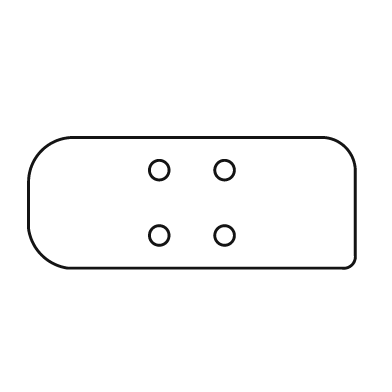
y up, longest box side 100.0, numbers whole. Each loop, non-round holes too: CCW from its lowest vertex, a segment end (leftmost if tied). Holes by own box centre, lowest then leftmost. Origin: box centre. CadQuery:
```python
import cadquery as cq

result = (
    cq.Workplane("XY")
    .moveTo(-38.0, -20.0)
    .lineTo(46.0, -20.0)
    .threePointArc((49.0, -19.0), (50.0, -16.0))
    .lineTo(50.0, 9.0)
    .threePointArc((47.0, 17.0), (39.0, 20.0))
    .lineTo(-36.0, 20.0)
    .threePointArc((-46.0, 16.0), (-50.0, 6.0))
    .lineTo(-50.0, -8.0)
    .threePointArc((-46.0, -16.0), (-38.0, -20.0))
    .close()
    .moveTo(-10.0, -10.0)
    .circle(3.0)
    .moveTo(10.0, -10.0)
    .circle(3.0)
    .moveTo(-10.0, 10.0)
    .circle(3.0)
    .moveTo(10.0, 10.0)
    .circle(3.0)
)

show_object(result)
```